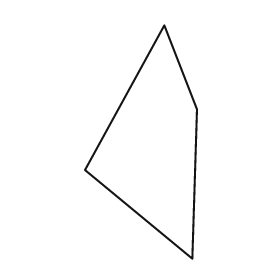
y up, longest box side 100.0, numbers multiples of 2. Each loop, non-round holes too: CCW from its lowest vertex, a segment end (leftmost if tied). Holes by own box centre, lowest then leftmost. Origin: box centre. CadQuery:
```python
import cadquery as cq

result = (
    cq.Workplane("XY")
    .moveTo(22.0, -50.0)
    .lineTo(24.0, 14.0)
    .lineTo(10.0, 50.0)
    .lineTo(-24.0, -12.0)
    .close()
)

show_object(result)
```